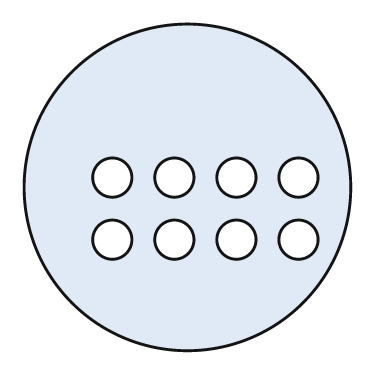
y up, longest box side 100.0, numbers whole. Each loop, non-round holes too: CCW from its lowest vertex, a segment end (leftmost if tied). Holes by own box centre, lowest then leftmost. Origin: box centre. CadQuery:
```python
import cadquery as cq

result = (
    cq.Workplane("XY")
    .moveTo(0.0, 0.0)
    .circle(50.0)
    .moveTo(-23.0, -16.0)
    .circle(6.0)
    .moveTo(-4.0, -16.0)
    .circle(6.0)
    .moveTo(15.0, -16.0)
    .circle(6.0)
    .moveTo(34.0, -16.0)
    .circle(6.0)
    .moveTo(-23.0, 3.0)
    .circle(6.0)
    .moveTo(-4.0, 3.0)
    .circle(6.0)
    .moveTo(15.0, 3.0)
    .circle(6.0)
    .moveTo(34.0, 3.0)
    .circle(6.0)
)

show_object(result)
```